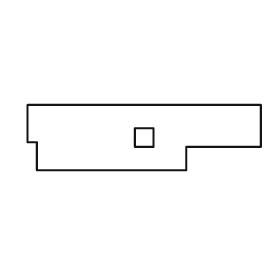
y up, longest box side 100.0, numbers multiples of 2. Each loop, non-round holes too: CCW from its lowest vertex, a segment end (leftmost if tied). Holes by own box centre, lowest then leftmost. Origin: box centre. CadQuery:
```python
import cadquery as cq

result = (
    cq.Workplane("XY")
    .moveTo(-46.0, -14.0)
    .lineTo(18.0, -14.0)
    .lineTo(18.0, -4.0)
    .lineTo(50.0, -4.0)
    .lineTo(50.0, 14.0)
    .lineTo(-50.0, 14.0)
    .lineTo(-50.0, -2.0)
    .lineTo(-46.0, -2.0)
    .close()
    .moveTo(-4.0, -4.0)
    .lineTo(4.0, -4.0)
    .lineTo(4.0, 4.0)
    .lineTo(-4.0, 4.0)
    .close()
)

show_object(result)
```